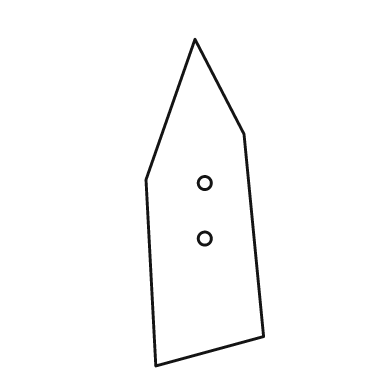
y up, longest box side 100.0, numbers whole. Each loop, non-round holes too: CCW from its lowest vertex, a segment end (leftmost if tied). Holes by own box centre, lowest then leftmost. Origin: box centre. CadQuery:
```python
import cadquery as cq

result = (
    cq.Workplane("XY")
    .moveTo(-15.0, -50.0)
    .lineTo(18.0, -41.0)
    .lineTo(12.0, 21.0)
    .lineTo(-3.0, 50.0)
    .lineTo(-18.0, 7.0)
    .close()
    .moveTo(0.0, -11.0)
    .circle(2.0)
    .moveTo(0.0, 6.0)
    .circle(2.0)
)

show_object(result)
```